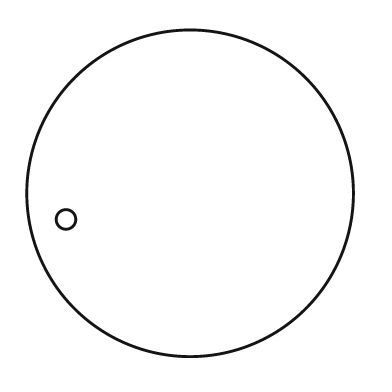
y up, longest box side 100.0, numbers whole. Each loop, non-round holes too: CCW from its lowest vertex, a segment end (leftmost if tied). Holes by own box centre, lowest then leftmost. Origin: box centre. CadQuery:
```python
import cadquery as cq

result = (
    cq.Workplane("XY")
    .moveTo(0.0, 0.0)
    .circle(50.0)
    .moveTo(-38.0, -8.0)
    .circle(3.0)
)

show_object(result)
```